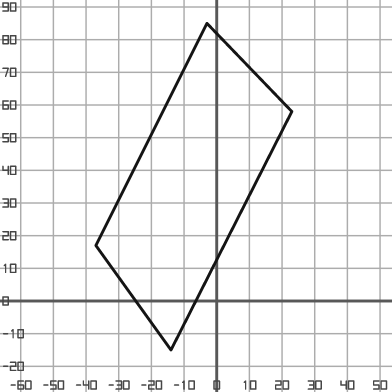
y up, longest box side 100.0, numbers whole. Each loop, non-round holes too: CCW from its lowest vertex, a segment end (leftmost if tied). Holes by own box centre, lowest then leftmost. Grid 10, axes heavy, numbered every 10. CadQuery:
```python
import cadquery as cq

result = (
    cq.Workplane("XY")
    .moveTo(-14.0, -15.0)
    .lineTo(23.0, 58.0)
    .lineTo(-3.0, 85.0)
    .lineTo(-37.0, 17.0)
    .close()
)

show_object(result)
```